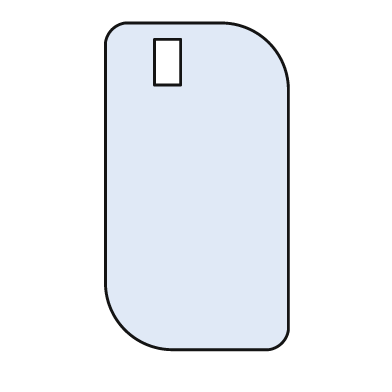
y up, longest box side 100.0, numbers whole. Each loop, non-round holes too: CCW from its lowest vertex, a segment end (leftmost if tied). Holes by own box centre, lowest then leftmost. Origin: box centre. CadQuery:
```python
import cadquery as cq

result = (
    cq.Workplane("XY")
    .moveTo(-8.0, -50.0)
    .lineTo(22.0, -50.0)
    .threePointArc((26.0, -48.0), (28.0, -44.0))
    .lineTo(28.0, 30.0)
    .threePointArc((22.0, 44.0), (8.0, 50.0))
    .lineTo(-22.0, 50.0)
    .threePointArc((-26.0, 48.0), (-28.0, 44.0))
    .lineTo(-28.0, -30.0)
    .threePointArc((-22.0, -44.0), (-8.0, -50.0))
    .close()
    .moveTo(-13.0, 31.0)
    .lineTo(-5.0, 31.0)
    .lineTo(-5.0, 45.0)
    .lineTo(-13.0, 45.0)
    .close()
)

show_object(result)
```